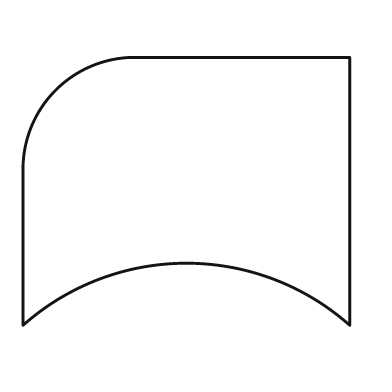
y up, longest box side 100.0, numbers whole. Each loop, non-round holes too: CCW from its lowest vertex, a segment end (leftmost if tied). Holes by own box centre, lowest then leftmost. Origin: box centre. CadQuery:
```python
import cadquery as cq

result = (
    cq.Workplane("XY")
    .moveTo(-50.0, -41.0)
    .threePointArc((0.0, -22.0), (50.0, -41.0))
    .lineTo(50.0, 41.0)
    .lineTo(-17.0, 41.0)
    .threePointArc((-40.0, 31.0), (-50.0, 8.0))
    .close()
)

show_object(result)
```